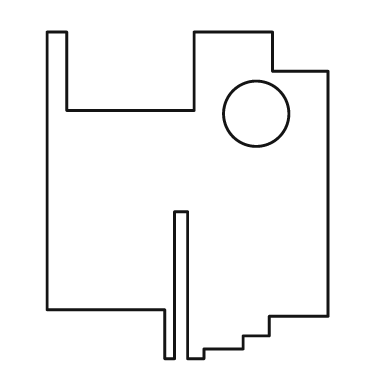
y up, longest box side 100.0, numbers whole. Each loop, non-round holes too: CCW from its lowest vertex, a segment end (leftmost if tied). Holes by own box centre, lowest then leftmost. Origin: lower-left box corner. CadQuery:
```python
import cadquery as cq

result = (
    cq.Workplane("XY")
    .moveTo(36.0, 0.0)
    .lineTo(39.0, 0.0)
    .lineTo(39.0, 45.0)
    .lineTo(43.0, 45.0)
    .lineTo(43.0, 0.0)
    .lineTo(48.0, 0.0)
    .lineTo(48.0, 3.0)
    .lineTo(60.0, 3.0)
    .lineTo(60.0, 7.0)
    .lineTo(68.0, 7.0)
    .lineTo(68.0, 13.0)
    .lineTo(86.0, 13.0)
    .lineTo(86.0, 88.0)
    .lineTo(69.0, 88.0)
    .lineTo(69.0, 100.0)
    .lineTo(45.0, 100.0)
    .lineTo(45.0, 76.0)
    .lineTo(6.0, 76.0)
    .lineTo(6.0, 100.0)
    .lineTo(0.0, 100.0)
    .lineTo(0.0, 15.0)
    .lineTo(36.0, 15.0)
    .close()
    .moveTo(64.0, 75.0)
    .circle(10.0)
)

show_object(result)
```